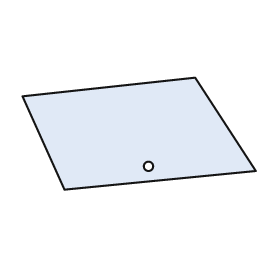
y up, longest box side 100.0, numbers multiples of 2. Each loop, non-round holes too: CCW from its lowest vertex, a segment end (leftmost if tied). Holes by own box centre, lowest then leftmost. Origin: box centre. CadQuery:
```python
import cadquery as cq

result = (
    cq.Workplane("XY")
    .moveTo(-32.0, -24.0)
    .lineTo(50.0, -16.0)
    .lineTo(24.0, 24.0)
    .lineTo(-50.0, 16.0)
    .close()
    .moveTo(4.0, -14.0)
    .circle(2.0)
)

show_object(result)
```